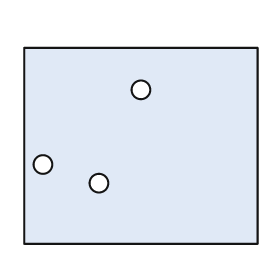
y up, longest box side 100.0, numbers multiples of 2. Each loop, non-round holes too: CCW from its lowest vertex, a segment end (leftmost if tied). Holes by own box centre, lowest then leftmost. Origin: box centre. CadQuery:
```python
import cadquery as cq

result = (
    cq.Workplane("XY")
    .moveTo(-50.0, -42.0)
    .lineTo(50.0, -42.0)
    .lineTo(50.0, 42.0)
    .lineTo(-50.0, 42.0)
    .close()
    .moveTo(-18.0, -16.0)
    .circle(4.0)
    .moveTo(-42.0, -8.0)
    .circle(4.0)
    .moveTo(0.0, 24.0)
    .circle(4.0)
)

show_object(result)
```